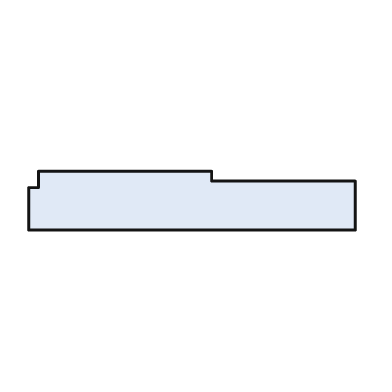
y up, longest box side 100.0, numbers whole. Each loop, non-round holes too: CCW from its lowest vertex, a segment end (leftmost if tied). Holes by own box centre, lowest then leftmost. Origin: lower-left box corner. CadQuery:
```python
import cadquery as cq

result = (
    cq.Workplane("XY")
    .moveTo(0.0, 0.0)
    .lineTo(100.0, 0.0)
    .lineTo(100.0, 15.0)
    .lineTo(56.0, 15.0)
    .lineTo(56.0, 18.0)
    .lineTo(3.0, 18.0)
    .lineTo(3.0, 13.0)
    .lineTo(0.0, 13.0)
    .close()
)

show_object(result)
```